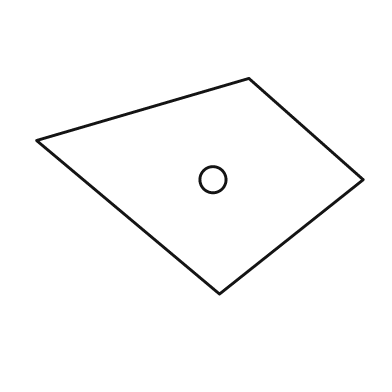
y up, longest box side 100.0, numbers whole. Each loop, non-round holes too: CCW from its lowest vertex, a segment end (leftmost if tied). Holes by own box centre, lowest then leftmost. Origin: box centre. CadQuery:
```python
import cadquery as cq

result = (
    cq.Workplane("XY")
    .moveTo(6.0, -33.0)
    .lineTo(50.0, 2.0)
    .lineTo(15.0, 33.0)
    .lineTo(-50.0, 14.0)
    .close()
    .moveTo(4.0, 2.0)
    .circle(4.0)
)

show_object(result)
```